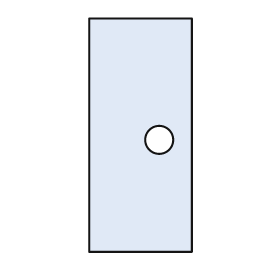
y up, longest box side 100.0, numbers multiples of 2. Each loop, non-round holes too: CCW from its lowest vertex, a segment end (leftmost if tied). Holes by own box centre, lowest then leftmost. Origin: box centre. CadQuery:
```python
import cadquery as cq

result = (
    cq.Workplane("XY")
    .moveTo(-22.0, -50.0)
    .lineTo(22.0, -50.0)
    .lineTo(22.0, 50.0)
    .lineTo(-22.0, 50.0)
    .close()
    .moveTo(8.0, -2.0)
    .circle(6.0)
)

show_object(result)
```